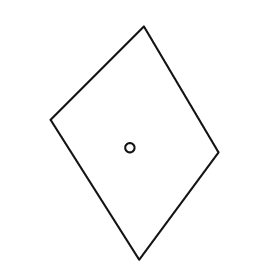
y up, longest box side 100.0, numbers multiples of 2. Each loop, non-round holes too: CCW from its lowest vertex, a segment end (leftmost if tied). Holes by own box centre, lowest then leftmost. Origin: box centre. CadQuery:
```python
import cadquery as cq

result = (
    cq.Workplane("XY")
    .moveTo(2.0, -50.0)
    .lineTo(36.0, -4.0)
    .lineTo(4.0, 50.0)
    .lineTo(-36.0, 10.0)
    .close()
    .moveTo(-2.0, -2.0)
    .circle(2.0)
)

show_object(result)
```